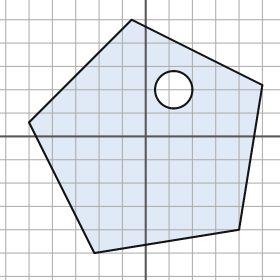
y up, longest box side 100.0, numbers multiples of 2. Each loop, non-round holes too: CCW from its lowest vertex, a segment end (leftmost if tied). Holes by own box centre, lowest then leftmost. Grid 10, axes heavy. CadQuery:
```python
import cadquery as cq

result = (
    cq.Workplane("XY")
    .moveTo(-22.0, -50.0)
    .lineTo(40.0, -40.0)
    .lineTo(50.0, 22.0)
    .lineTo(-6.0, 50.0)
    .lineTo(-50.0, 6.0)
    .close()
    .moveTo(12.0, 20.0)
    .circle(8.0)
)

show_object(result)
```